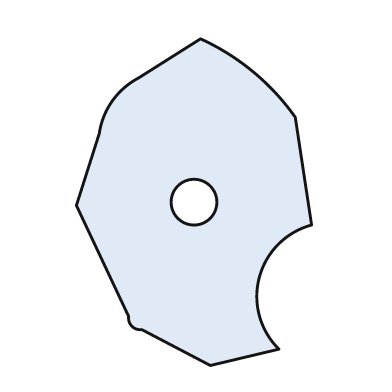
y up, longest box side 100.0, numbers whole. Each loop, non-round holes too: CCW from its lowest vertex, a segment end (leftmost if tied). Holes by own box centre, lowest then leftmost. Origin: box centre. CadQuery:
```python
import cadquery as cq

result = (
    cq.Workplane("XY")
    .moveTo(5.0, -50.0)
    .lineTo(26.0, -45.0)
    .threePointArc((20.0, -23.0), (36.0, -7.0))
    .lineTo(31.0, 26.0)
    .threePointArc((18.0, 40.0), (2.0, 50.0))
    .lineTo(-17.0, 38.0)
    .threePointArc((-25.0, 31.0), (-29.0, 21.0))
    .lineTo(-36.0, -1.0)
    .lineTo(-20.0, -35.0)
    .threePointArc((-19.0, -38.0), (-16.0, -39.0))
    .close()
    .moveTo(0.0, 0.0)
    .circle(7.0)
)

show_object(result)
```